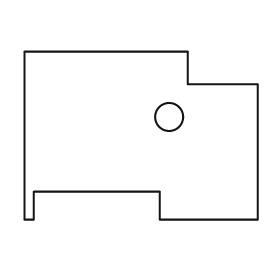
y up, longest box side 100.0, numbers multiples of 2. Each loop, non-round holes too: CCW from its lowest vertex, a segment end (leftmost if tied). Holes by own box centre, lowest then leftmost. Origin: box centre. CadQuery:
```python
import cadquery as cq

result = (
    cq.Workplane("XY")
    .moveTo(-50.0, -36.0)
    .lineTo(-46.0, -36.0)
    .lineTo(-46.0, -24.0)
    .lineTo(8.0, -24.0)
    .lineTo(8.0, -36.0)
    .lineTo(50.0, -36.0)
    .lineTo(50.0, 22.0)
    .lineTo(20.0, 22.0)
    .lineTo(20.0, 36.0)
    .lineTo(-50.0, 36.0)
    .close()
    .moveTo(12.0, 8.0)
    .circle(6.0)
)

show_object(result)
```